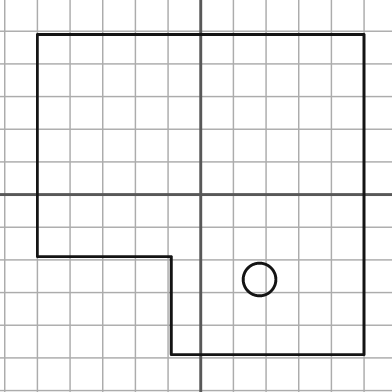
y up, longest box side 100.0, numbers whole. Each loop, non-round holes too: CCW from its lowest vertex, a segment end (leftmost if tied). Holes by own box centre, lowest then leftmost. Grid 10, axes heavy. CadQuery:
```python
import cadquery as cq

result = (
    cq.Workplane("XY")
    .moveTo(-9.0, -49.0)
    .lineTo(50.0, -49.0)
    .lineTo(50.0, 49.0)
    .lineTo(-50.0, 49.0)
    .lineTo(-50.0, -19.0)
    .lineTo(-9.0, -19.0)
    .close()
    .moveTo(18.0, -26.0)
    .circle(5.0)
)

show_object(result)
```